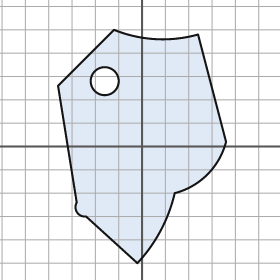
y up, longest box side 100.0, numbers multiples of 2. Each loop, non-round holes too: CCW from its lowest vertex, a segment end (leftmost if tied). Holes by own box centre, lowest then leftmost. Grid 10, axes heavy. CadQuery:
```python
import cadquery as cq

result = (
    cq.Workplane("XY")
    .moveTo(-2.0, -50.0)
    .threePointArc((8.0, -36.0), (14.0, -20.0))
    .threePointArc((28.0, -12.0), (36.0, 2.0))
    .lineTo(24.0, 48.0)
    .threePointArc((6.0, 46.0), (-12.0, 50.0))
    .lineTo(-36.0, 26.0)
    .lineTo(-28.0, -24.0)
    .threePointArc((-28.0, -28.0), (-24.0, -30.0))
    .close()
    .moveTo(-16.0, 28.0)
    .circle(6.0)
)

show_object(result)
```